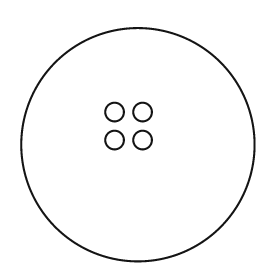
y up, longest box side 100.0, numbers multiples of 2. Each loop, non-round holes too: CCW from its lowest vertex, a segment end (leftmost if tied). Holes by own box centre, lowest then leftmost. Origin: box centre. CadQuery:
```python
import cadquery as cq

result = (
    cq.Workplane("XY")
    .moveTo(0.0, 0.0)
    .circle(50.0)
    .moveTo(-10.0, 2.0)
    .circle(4.0)
    .moveTo(2.0, 2.0)
    .circle(4.0)
    .moveTo(-10.0, 14.0)
    .circle(4.0)
    .moveTo(2.0, 14.0)
    .circle(4.0)
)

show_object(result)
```